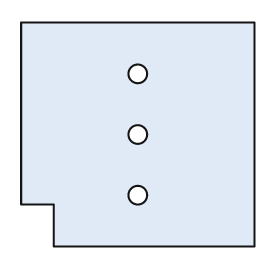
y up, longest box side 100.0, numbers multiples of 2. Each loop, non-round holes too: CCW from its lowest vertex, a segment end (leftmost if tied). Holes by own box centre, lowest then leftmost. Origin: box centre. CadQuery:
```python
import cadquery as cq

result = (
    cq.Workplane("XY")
    .moveTo(-36.0, -48.0)
    .lineTo(50.0, -48.0)
    .lineTo(50.0, 48.0)
    .lineTo(-50.0, 48.0)
    .lineTo(-50.0, -30.0)
    .lineTo(-36.0, -30.0)
    .close()
    .moveTo(0.0, -26.0)
    .circle(4.0)
    .moveTo(0.0, 0.0)
    .circle(4.0)
    .moveTo(0.0, 26.0)
    .circle(4.0)
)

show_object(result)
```